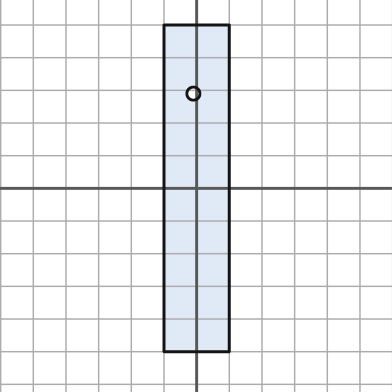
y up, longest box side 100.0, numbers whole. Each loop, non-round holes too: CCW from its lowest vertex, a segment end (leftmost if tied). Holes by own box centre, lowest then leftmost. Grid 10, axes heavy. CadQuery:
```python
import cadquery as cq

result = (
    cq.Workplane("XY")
    .moveTo(-10.0, -50.0)
    .lineTo(10.0, -50.0)
    .lineTo(10.0, 50.0)
    .lineTo(-10.0, 50.0)
    .close()
    .moveTo(-1.0, 29.0)
    .circle(2.0)
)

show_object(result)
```